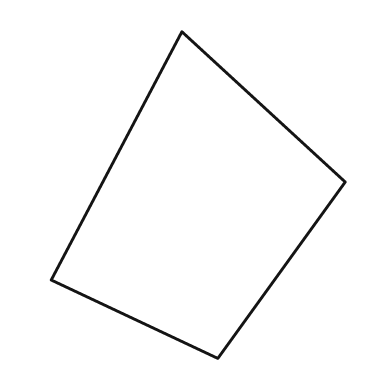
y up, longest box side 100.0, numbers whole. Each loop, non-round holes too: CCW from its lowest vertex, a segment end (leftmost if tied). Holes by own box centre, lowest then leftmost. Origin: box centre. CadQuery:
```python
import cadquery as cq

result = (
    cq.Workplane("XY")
    .moveTo(6.0, -50.0)
    .lineTo(45.0, 4.0)
    .lineTo(-5.0, 50.0)
    .lineTo(-45.0, -26.0)
    .close()
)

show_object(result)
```